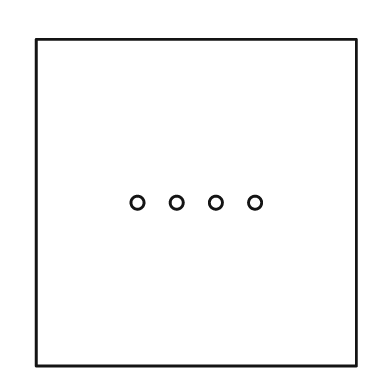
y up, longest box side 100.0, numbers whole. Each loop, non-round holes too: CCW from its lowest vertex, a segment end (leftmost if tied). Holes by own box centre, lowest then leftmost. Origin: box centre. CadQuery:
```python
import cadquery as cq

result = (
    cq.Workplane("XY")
    .moveTo(-49.0, -50.0)
    .lineTo(49.0, -50.0)
    .lineTo(49.0, 50.0)
    .lineTo(-49.0, 50.0)
    .close()
    .moveTo(-18.0, 0.0)
    .circle(2.0)
    .moveTo(-6.0, 0.0)
    .circle(2.0)
    .moveTo(6.0, 0.0)
    .circle(2.0)
    .moveTo(18.0, 0.0)
    .circle(2.0)
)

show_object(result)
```